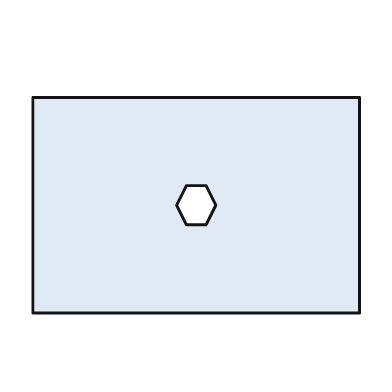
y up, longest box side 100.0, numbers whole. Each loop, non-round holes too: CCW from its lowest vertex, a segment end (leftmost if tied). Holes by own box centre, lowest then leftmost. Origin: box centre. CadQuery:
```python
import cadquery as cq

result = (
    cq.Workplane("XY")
    .moveTo(-50.0, -33.0)
    .lineTo(50.0, -33.0)
    .lineTo(50.0, 33.0)
    .lineTo(-50.0, 33.0)
    .close()
    .moveTo(-3.0, -6.0)
    .lineTo(3.0, -6.0)
    .lineTo(6.0, 0.0)
    .lineTo(3.0, 6.0)
    .lineTo(-3.0, 6.0)
    .lineTo(-6.0, 0.0)
    .close()
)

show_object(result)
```